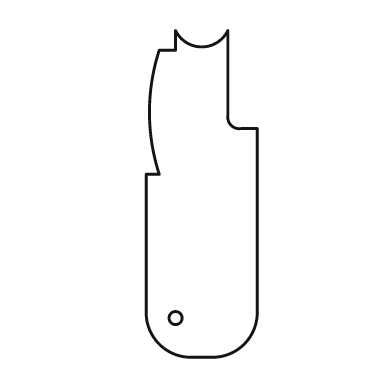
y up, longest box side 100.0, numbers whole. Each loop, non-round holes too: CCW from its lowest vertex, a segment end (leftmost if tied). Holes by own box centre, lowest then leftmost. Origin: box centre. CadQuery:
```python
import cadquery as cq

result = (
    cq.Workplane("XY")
    .moveTo(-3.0, -50.0)
    .lineTo(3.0, -50.0)
    .threePointArc((13.0, -46.0), (17.0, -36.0))
    .lineTo(17.0, 20.0)
    .lineTo(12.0, 20.0)
    .threePointArc((9.0, 21.0), (8.0, 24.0))
    .lineTo(8.0, 50.0)
    .threePointArc((0.0, 45.0), (-8.0, 50.0))
    .lineTo(-8.0, 44.0)
    .lineTo(-13.0, 44.0)
    .threePointArc((-16.0, 25.0), (-13.0, 6.0))
    .lineTo(-17.0, 6.0)
    .lineTo(-17.0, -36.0)
    .threePointArc((-13.0, -46.0), (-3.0, -50.0))
    .close()
    .moveTo(-8.0, -38.0)
    .circle(2.0)
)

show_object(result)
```